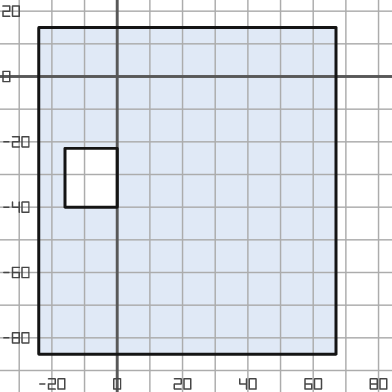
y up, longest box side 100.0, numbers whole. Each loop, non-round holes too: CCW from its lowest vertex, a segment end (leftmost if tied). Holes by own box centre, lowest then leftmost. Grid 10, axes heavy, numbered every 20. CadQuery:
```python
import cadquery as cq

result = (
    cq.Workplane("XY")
    .moveTo(-24.0, -85.0)
    .lineTo(67.0, -85.0)
    .lineTo(67.0, 15.0)
    .lineTo(-24.0, 15.0)
    .close()
    .moveTo(-16.0, -40.0)
    .lineTo(0.0, -40.0)
    .lineTo(0.0, -22.0)
    .lineTo(-16.0, -22.0)
    .close()
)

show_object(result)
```